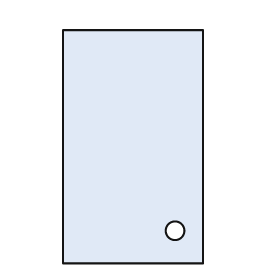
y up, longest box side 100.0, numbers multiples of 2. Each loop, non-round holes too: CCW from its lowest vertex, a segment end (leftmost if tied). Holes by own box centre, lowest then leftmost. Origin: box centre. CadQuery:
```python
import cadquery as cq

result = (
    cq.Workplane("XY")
    .moveTo(-30.0, -50.0)
    .lineTo(30.0, -50.0)
    .lineTo(30.0, 50.0)
    .lineTo(-30.0, 50.0)
    .close()
    .moveTo(18.0, -36.0)
    .circle(4.0)
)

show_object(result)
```